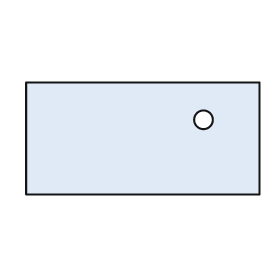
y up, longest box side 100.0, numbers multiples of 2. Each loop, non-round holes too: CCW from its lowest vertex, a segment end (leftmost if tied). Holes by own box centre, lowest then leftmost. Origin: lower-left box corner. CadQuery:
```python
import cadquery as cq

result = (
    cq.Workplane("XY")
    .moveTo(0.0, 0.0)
    .lineTo(100.0, 0.0)
    .lineTo(100.0, 48.0)
    .lineTo(0.0, 48.0)
    .close()
    .moveTo(76.0, 32.0)
    .circle(4.0)
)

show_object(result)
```